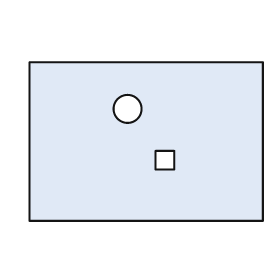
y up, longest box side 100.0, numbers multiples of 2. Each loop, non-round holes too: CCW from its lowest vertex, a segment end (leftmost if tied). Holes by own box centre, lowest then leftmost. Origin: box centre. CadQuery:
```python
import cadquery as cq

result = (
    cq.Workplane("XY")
    .moveTo(-50.0, -34.0)
    .lineTo(50.0, -34.0)
    .lineTo(50.0, 34.0)
    .lineTo(-50.0, 34.0)
    .close()
    .moveTo(4.0, -12.0)
    .lineTo(12.0, -12.0)
    .lineTo(12.0, -4.0)
    .lineTo(4.0, -4.0)
    .close()
    .moveTo(-8.0, 14.0)
    .circle(6.0)
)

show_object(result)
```